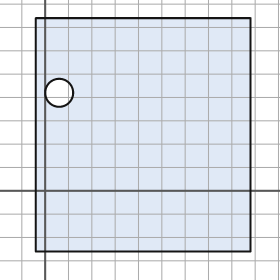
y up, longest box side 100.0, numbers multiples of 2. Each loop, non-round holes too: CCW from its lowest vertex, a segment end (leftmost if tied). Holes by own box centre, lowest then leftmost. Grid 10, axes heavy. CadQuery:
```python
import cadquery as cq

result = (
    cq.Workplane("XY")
    .moveTo(-4.0, -26.0)
    .lineTo(88.0, -26.0)
    .lineTo(88.0, 74.0)
    .lineTo(-4.0, 74.0)
    .close()
    .moveTo(6.0, 42.0)
    .circle(6.0)
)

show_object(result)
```